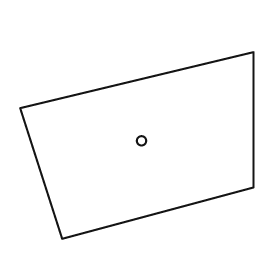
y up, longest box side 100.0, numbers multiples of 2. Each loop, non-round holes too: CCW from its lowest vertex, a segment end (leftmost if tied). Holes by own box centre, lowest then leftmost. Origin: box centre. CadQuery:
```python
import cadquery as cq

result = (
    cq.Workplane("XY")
    .moveTo(-32.0, -40.0)
    .lineTo(50.0, -18.0)
    .lineTo(50.0, 40.0)
    .lineTo(-50.0, 16.0)
    .close()
    .moveTo(2.0, 2.0)
    .circle(2.0)
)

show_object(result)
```